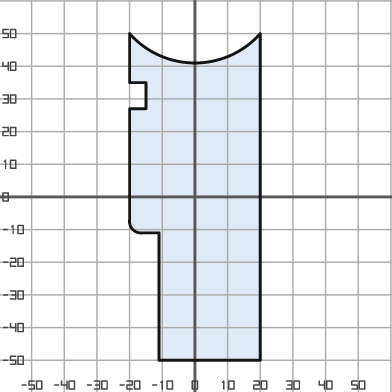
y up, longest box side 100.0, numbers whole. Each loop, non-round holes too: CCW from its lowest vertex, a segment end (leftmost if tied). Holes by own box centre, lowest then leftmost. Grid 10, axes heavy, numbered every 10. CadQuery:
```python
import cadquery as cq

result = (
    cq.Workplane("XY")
    .moveTo(-11.0, -50.0)
    .lineTo(20.0, -50.0)
    .lineTo(20.0, 50.0)
    .threePointArc((0.0, 41.0), (-20.0, 50.0))
    .lineTo(-20.0, 35.0)
    .lineTo(-15.0, 35.0)
    .lineTo(-15.0, 27.0)
    .lineTo(-20.0, 27.0)
    .lineTo(-20.0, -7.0)
    .threePointArc((-19.0, -10.0), (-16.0, -11.0))
    .lineTo(-11.0, -11.0)
    .close()
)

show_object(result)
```